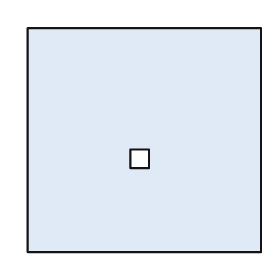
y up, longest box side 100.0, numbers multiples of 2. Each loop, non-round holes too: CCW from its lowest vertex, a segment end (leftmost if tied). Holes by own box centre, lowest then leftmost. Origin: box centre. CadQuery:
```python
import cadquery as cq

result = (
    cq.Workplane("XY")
    .moveTo(-50.0, -48.0)
    .lineTo(50.0, -48.0)
    .lineTo(50.0, 48.0)
    .lineTo(-50.0, 48.0)
    .close()
    .moveTo(-6.0, -12.0)
    .lineTo(2.0, -12.0)
    .lineTo(2.0, -4.0)
    .lineTo(-6.0, -4.0)
    .close()
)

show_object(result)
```